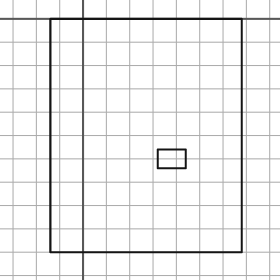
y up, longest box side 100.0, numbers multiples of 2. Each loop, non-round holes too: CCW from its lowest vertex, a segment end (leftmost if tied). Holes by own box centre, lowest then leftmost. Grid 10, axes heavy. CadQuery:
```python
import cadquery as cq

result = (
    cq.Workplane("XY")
    .moveTo(-14.0, -100.0)
    .lineTo(68.0, -100.0)
    .lineTo(68.0, 0.0)
    .lineTo(-14.0, 0.0)
    .close()
    .moveTo(32.0, -64.0)
    .lineTo(44.0, -64.0)
    .lineTo(44.0, -56.0)
    .lineTo(32.0, -56.0)
    .close()
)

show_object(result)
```